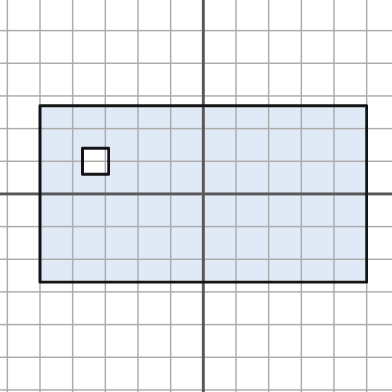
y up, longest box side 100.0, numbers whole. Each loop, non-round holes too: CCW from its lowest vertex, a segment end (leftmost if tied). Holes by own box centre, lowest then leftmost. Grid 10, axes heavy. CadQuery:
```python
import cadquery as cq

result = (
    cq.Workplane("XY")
    .moveTo(-50.0, -27.0)
    .lineTo(50.0, -27.0)
    .lineTo(50.0, 27.0)
    .lineTo(-50.0, 27.0)
    .close()
    .moveTo(-37.0, 6.0)
    .lineTo(-29.0, 6.0)
    .lineTo(-29.0, 14.0)
    .lineTo(-37.0, 14.0)
    .close()
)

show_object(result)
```